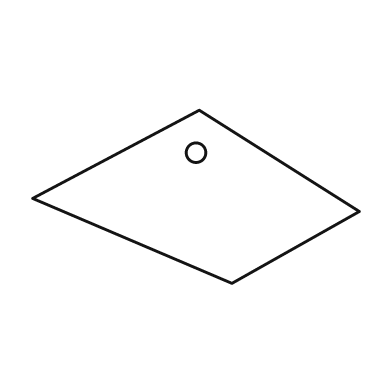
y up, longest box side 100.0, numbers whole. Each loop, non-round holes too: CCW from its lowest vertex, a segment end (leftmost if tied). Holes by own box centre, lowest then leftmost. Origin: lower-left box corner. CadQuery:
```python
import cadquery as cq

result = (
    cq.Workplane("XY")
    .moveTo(61.0, 0.0)
    .lineTo(100.0, 22.0)
    .lineTo(51.0, 53.0)
    .lineTo(0.0, 26.0)
    .close()
    .moveTo(50.0, 40.0)
    .circle(3.0)
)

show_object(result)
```